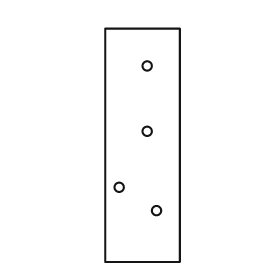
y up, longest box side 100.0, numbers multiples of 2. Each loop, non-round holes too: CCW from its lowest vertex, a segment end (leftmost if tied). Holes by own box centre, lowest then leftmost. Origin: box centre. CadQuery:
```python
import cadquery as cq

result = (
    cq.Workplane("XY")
    .moveTo(-16.0, -50.0)
    .lineTo(16.0, -50.0)
    .lineTo(16.0, 50.0)
    .lineTo(-16.0, 50.0)
    .close()
    .moveTo(6.0, -28.0)
    .circle(2.0)
    .moveTo(-10.0, -18.0)
    .circle(2.0)
    .moveTo(2.0, 6.0)
    .circle(2.0)
    .moveTo(2.0, 34.0)
    .circle(2.0)
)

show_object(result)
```